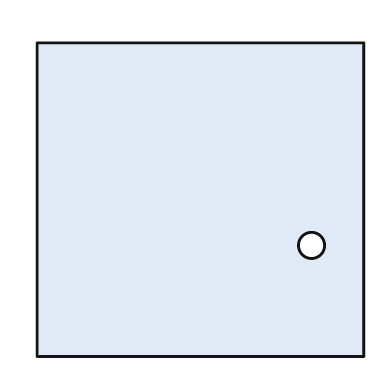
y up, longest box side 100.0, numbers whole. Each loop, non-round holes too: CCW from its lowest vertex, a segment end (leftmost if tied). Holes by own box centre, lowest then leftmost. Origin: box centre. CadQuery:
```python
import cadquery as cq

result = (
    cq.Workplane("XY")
    .moveTo(-50.0, -48.0)
    .lineTo(50.0, -48.0)
    .lineTo(50.0, 48.0)
    .lineTo(-50.0, 48.0)
    .close()
    .moveTo(34.0, -14.0)
    .circle(4.0)
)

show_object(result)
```